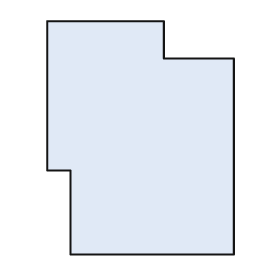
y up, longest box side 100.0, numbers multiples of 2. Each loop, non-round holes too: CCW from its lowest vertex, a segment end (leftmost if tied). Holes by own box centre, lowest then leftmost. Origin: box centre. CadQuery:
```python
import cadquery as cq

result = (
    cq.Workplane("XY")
    .moveTo(-30.0, -50.0)
    .lineTo(40.0, -50.0)
    .lineTo(40.0, 34.0)
    .lineTo(10.0, 34.0)
    .lineTo(10.0, 50.0)
    .lineTo(-40.0, 50.0)
    .lineTo(-40.0, -14.0)
    .lineTo(-30.0, -14.0)
    .close()
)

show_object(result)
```